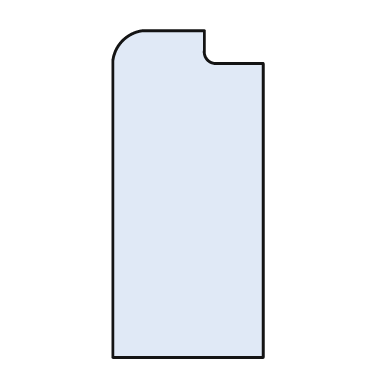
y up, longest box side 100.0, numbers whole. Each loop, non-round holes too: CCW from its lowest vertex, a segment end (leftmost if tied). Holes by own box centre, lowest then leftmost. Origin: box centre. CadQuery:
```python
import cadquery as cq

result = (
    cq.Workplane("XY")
    .moveTo(-23.0, -50.0)
    .lineTo(23.0, -50.0)
    .lineTo(23.0, 40.0)
    .lineTo(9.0, 40.0)
    .threePointArc((6.0, 41.0), (5.0, 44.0))
    .lineTo(5.0, 50.0)
    .lineTo(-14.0, 50.0)
    .threePointArc((-20.0, 47.0), (-23.0, 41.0))
    .close()
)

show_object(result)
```